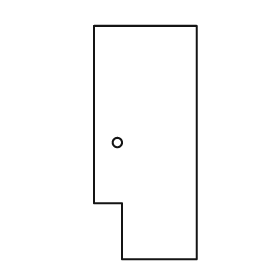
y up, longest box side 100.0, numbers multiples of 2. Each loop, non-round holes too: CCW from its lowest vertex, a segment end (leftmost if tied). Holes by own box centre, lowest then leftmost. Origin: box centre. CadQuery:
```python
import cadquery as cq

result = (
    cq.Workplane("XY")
    .moveTo(-10.0, -50.0)
    .lineTo(22.0, -50.0)
    .lineTo(22.0, 50.0)
    .lineTo(-22.0, 50.0)
    .lineTo(-22.0, -26.0)
    .lineTo(-10.0, -26.0)
    .close()
    .moveTo(-12.0, 0.0)
    .circle(2.0)
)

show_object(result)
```